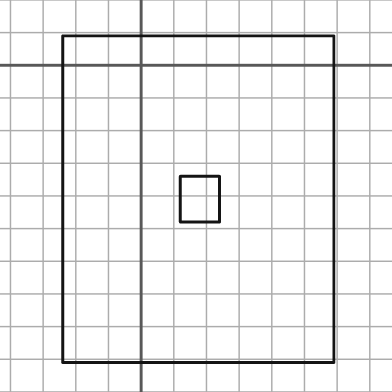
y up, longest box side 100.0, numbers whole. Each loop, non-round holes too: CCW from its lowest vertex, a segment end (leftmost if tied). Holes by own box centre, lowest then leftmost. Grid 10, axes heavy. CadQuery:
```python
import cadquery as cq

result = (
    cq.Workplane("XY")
    .moveTo(-24.0, -91.0)
    .lineTo(59.0, -91.0)
    .lineTo(59.0, 9.0)
    .lineTo(-24.0, 9.0)
    .close()
    .moveTo(12.0, -48.0)
    .lineTo(24.0, -48.0)
    .lineTo(24.0, -34.0)
    .lineTo(12.0, -34.0)
    .close()
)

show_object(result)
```